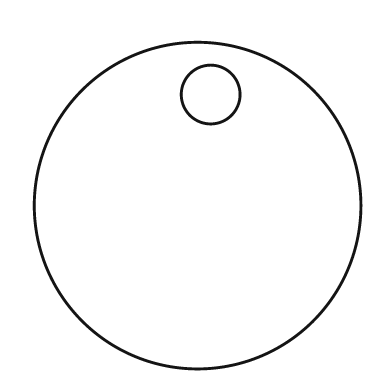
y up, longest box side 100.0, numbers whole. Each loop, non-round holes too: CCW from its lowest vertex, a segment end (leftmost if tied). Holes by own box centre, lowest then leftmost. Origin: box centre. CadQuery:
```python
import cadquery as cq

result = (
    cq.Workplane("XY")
    .moveTo(0.0, 0.0)
    .circle(50.0)
    .moveTo(4.0, 34.0)
    .circle(9.0)
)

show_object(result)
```